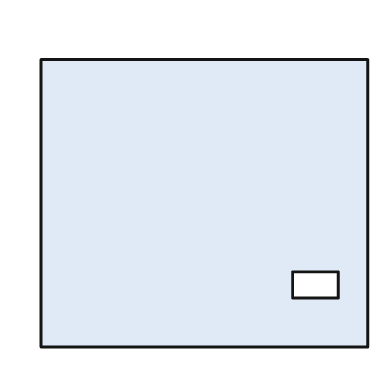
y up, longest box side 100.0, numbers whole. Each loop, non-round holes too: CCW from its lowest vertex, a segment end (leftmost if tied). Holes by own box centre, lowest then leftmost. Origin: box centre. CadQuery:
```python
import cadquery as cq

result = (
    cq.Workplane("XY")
    .moveTo(-50.0, -44.0)
    .lineTo(50.0, -44.0)
    .lineTo(50.0, 44.0)
    .lineTo(-50.0, 44.0)
    .close()
    .moveTo(27.0, -29.0)
    .lineTo(41.0, -29.0)
    .lineTo(41.0, -21.0)
    .lineTo(27.0, -21.0)
    .close()
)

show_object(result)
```